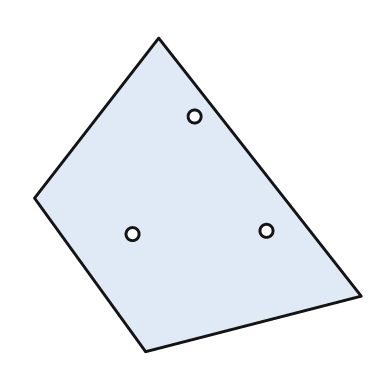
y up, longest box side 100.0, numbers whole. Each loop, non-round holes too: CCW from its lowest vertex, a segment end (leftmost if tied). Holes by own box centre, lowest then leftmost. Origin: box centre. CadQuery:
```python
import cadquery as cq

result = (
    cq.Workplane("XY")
    .moveTo(-16.0, -48.0)
    .lineTo(50.0, -31.0)
    .lineTo(-12.0, 48.0)
    .lineTo(-50.0, -1.0)
    .close()
    .moveTo(-20.0, -12.0)
    .circle(2.0)
    .moveTo(21.0, -11.0)
    .circle(2.0)
    .moveTo(-1.0, 24.0)
    .circle(2.0)
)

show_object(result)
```